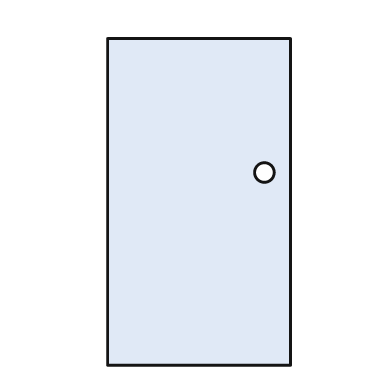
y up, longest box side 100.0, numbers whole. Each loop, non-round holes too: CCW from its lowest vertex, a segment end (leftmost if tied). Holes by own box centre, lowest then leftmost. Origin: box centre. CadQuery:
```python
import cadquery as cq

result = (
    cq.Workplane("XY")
    .moveTo(-28.0, -50.0)
    .lineTo(28.0, -50.0)
    .lineTo(28.0, 50.0)
    .lineTo(-28.0, 50.0)
    .close()
    .moveTo(20.0, 9.0)
    .circle(3.0)
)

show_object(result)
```